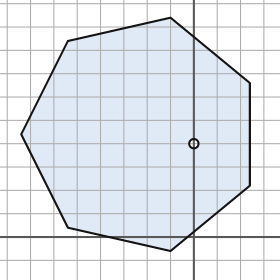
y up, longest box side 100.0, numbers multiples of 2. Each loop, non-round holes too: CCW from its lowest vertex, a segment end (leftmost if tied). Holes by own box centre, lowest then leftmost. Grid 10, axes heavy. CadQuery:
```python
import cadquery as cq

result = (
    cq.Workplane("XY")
    .moveTo(-10.0, -6.0)
    .lineTo(24.0, 22.0)
    .lineTo(24.0, 66.0)
    .lineTo(-10.0, 94.0)
    .lineTo(-54.0, 84.0)
    .lineTo(-74.0, 44.0)
    .lineTo(-54.0, 4.0)
    .close()
    .moveTo(0.0, 40.0)
    .circle(2.0)
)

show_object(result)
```